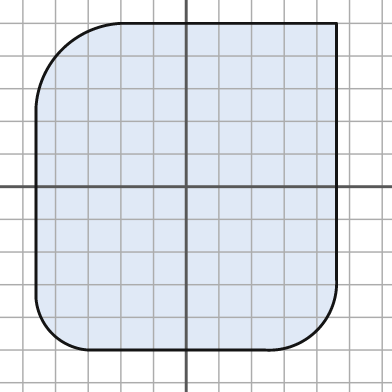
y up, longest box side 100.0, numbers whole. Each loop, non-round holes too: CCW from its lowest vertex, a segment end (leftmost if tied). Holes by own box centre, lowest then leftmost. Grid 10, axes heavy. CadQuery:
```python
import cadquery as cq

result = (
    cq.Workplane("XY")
    .moveTo(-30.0, -50.0)
    .lineTo(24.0, -50.0)
    .threePointArc((40.0, -44.0), (46.0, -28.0))
    .lineTo(46.0, 50.0)
    .lineTo(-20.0, 50.0)
    .threePointArc((-38.0, 42.0), (-46.0, 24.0))
    .lineTo(-46.0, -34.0)
    .threePointArc((-41.0, -45.0), (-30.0, -50.0))
    .close()
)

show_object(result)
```